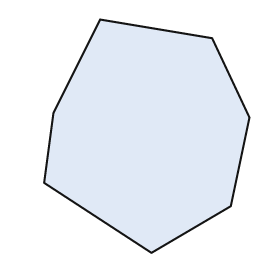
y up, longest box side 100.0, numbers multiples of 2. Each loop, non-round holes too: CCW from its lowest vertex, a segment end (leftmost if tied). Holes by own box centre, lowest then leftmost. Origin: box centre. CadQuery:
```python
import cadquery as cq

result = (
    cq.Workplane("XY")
    .moveTo(2.0, -50.0)
    .lineTo(36.0, -30.0)
    .lineTo(44.0, 8.0)
    .lineTo(28.0, 42.0)
    .lineTo(-20.0, 50.0)
    .lineTo(-40.0, 10.0)
    .lineTo(-44.0, -20.0)
    .close()
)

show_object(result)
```